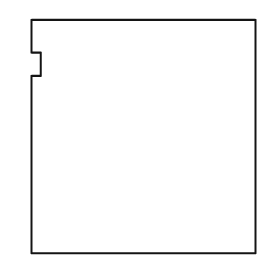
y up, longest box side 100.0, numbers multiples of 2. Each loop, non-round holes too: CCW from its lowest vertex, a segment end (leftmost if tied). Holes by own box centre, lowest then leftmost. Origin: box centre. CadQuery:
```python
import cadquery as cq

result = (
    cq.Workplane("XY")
    .moveTo(-48.0, -50.0)
    .lineTo(48.0, -50.0)
    .lineTo(48.0, 50.0)
    .lineTo(-48.0, 50.0)
    .lineTo(-48.0, 36.0)
    .lineTo(-44.0, 36.0)
    .lineTo(-44.0, 26.0)
    .lineTo(-48.0, 26.0)
    .close()
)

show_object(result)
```